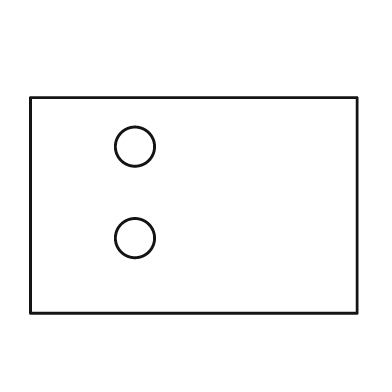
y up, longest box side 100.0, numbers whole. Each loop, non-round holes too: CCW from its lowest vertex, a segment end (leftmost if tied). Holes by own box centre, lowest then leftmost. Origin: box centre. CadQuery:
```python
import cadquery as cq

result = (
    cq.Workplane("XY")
    .moveTo(-50.0, -33.0)
    .lineTo(50.0, -33.0)
    .lineTo(50.0, 33.0)
    .lineTo(-50.0, 33.0)
    .close()
    .moveTo(-18.0, -10.0)
    .circle(6.0)
    .moveTo(-18.0, 18.0)
    .circle(6.0)
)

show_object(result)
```